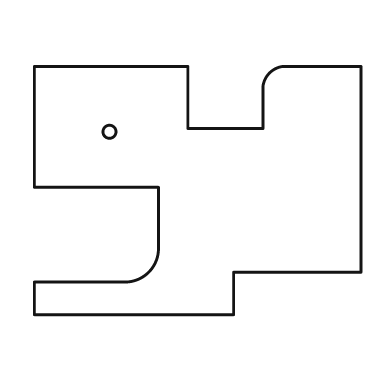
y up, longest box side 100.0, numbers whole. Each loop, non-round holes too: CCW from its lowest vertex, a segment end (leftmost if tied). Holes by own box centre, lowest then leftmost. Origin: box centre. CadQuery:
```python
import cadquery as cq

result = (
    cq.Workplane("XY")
    .moveTo(-50.0, -38.0)
    .lineTo(11.0, -38.0)
    .lineTo(11.0, -25.0)
    .lineTo(50.0, -25.0)
    .lineTo(50.0, 38.0)
    .lineTo(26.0, 38.0)
    .threePointArc((22.0, 36.0), (20.0, 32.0))
    .lineTo(20.0, 19.0)
    .lineTo(-3.0, 19.0)
    .lineTo(-3.0, 38.0)
    .lineTo(-50.0, 38.0)
    .lineTo(-50.0, 1.0)
    .lineTo(-12.0, 1.0)
    .lineTo(-12.0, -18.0)
    .threePointArc((-15.0, -25.0), (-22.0, -28.0))
    .lineTo(-50.0, -28.0)
    .close()
    .moveTo(-27.0, 18.0)
    .circle(2.0)
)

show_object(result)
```